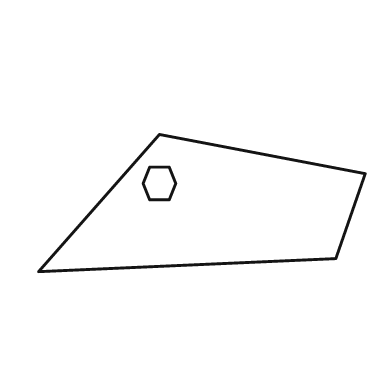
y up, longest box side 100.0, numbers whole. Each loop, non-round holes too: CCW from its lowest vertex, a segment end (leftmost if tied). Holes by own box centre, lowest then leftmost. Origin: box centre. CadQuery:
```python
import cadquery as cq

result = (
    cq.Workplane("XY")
    .moveTo(-50.0, -21.0)
    .lineTo(41.0, -17.0)
    .lineTo(50.0, 9.0)
    .lineTo(-13.0, 21.0)
    .close()
    .moveTo(-16.0, 1.0)
    .lineTo(-10.0, 1.0)
    .lineTo(-8.0, 6.0)
    .lineTo(-10.0, 11.0)
    .lineTo(-16.0, 11.0)
    .lineTo(-18.0, 6.0)
    .close()
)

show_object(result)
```